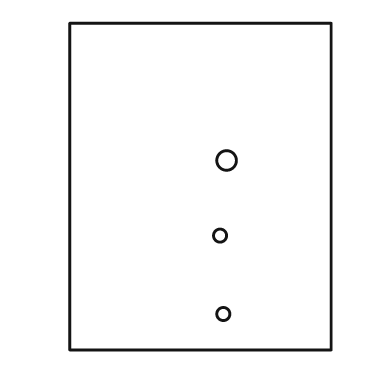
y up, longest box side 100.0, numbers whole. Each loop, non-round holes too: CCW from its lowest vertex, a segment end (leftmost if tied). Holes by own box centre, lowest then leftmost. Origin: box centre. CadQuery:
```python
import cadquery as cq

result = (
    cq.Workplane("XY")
    .moveTo(-40.0, -50.0)
    .lineTo(40.0, -50.0)
    .lineTo(40.0, 50.0)
    .lineTo(-40.0, 50.0)
    .close()
    .moveTo(7.0, -39.0)
    .circle(2.0)
    .moveTo(6.0, -15.0)
    .circle(2.0)
    .moveTo(8.0, 8.0)
    .circle(3.0)
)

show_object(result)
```